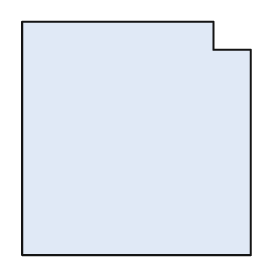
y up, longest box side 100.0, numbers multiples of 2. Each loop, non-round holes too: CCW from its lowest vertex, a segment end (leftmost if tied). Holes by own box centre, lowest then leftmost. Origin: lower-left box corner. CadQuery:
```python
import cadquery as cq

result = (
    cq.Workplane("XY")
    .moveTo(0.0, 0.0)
    .lineTo(98.0, 0.0)
    .lineTo(98.0, 88.0)
    .lineTo(82.0, 88.0)
    .lineTo(82.0, 100.0)
    .lineTo(0.0, 100.0)
    .close()
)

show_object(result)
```